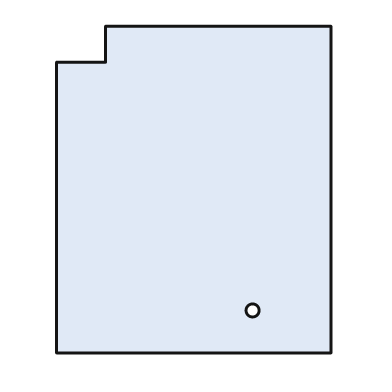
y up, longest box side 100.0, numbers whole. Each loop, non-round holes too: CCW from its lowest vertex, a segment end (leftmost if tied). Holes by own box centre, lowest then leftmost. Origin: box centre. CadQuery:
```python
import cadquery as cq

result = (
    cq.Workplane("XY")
    .moveTo(-42.0, -50.0)
    .lineTo(42.0, -50.0)
    .lineTo(42.0, 50.0)
    .lineTo(-27.0, 50.0)
    .lineTo(-27.0, 39.0)
    .lineTo(-42.0, 39.0)
    .close()
    .moveTo(18.0, -37.0)
    .circle(2.0)
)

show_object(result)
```